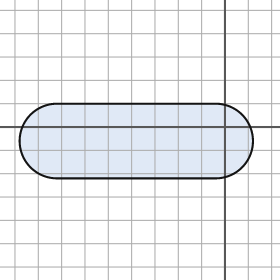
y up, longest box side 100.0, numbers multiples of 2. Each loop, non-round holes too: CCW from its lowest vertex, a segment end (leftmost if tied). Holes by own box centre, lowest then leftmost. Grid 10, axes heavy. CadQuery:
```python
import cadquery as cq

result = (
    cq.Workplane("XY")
    .moveTo(-72.0, -22.0)
    .lineTo(-4.0, -22.0)
    .threePointArc((12.0, -6.0), (-4.0, 10.0))
    .lineTo(-72.0, 10.0)
    .threePointArc((-88.0, -6.0), (-72.0, -22.0))
    .close()
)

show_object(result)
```